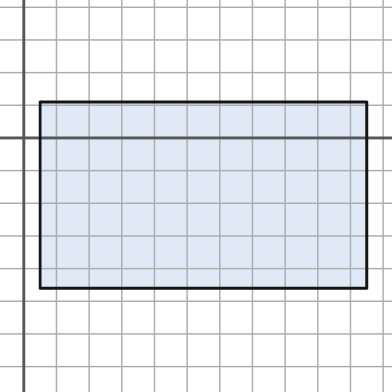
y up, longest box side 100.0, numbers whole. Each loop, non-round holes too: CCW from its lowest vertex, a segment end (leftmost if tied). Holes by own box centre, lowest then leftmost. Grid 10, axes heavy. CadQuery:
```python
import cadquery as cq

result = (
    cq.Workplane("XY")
    .moveTo(5.0, -46.0)
    .lineTo(105.0, -46.0)
    .lineTo(105.0, 11.0)
    .lineTo(5.0, 11.0)
    .close()
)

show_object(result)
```